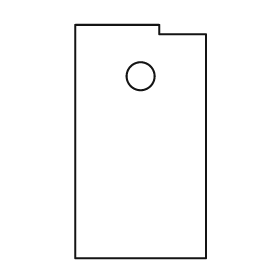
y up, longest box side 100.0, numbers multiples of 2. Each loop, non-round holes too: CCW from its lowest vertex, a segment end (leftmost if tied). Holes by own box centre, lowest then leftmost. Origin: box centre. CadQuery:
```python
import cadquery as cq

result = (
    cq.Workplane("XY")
    .moveTo(-28.0, -50.0)
    .lineTo(28.0, -50.0)
    .lineTo(28.0, 46.0)
    .lineTo(8.0, 46.0)
    .lineTo(8.0, 50.0)
    .lineTo(-28.0, 50.0)
    .close()
    .moveTo(0.0, 28.0)
    .circle(6.0)
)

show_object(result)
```